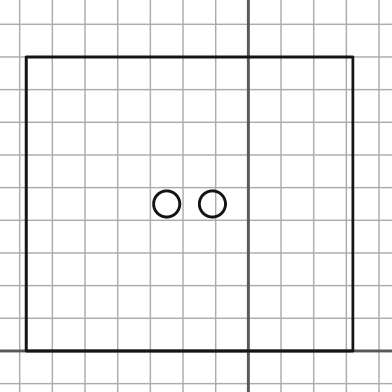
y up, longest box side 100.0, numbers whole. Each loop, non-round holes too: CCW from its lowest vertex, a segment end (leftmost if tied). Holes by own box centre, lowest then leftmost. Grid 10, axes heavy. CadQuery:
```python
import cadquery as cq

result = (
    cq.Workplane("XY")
    .moveTo(-68.0, 0.0)
    .lineTo(32.0, 0.0)
    .lineTo(32.0, 90.0)
    .lineTo(-68.0, 90.0)
    .close()
    .moveTo(-25.0, 45.0)
    .circle(4.0)
    .moveTo(-11.0, 45.0)
    .circle(4.0)
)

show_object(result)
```